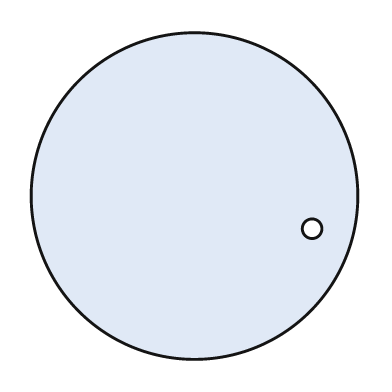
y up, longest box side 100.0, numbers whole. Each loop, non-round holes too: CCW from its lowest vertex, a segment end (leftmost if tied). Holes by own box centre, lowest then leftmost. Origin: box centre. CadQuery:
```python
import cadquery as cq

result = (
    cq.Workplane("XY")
    .moveTo(0.0, 0.0)
    .circle(50.0)
    .moveTo(36.0, -10.0)
    .circle(3.0)
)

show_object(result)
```